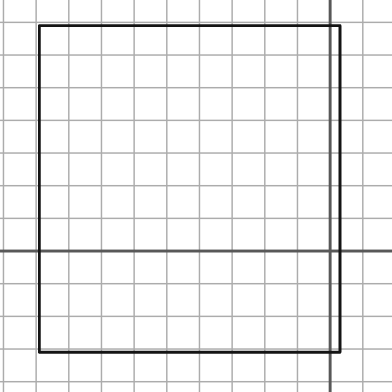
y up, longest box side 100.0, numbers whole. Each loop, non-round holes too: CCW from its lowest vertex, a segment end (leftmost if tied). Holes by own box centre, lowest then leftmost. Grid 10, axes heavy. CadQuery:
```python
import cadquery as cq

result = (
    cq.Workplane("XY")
    .moveTo(-89.0, -31.0)
    .lineTo(3.0, -31.0)
    .lineTo(3.0, 69.0)
    .lineTo(-89.0, 69.0)
    .close()
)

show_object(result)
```